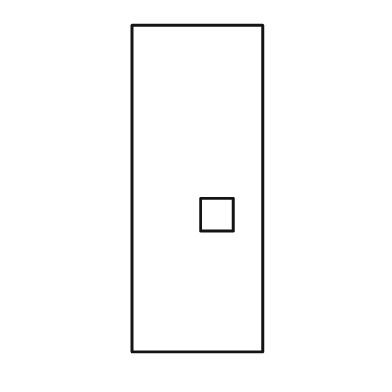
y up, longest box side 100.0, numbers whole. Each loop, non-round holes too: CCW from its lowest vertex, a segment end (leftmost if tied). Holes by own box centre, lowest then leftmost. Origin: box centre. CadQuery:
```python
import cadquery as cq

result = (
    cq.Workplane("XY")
    .moveTo(-20.0, -50.0)
    .lineTo(20.0, -50.0)
    .lineTo(20.0, 50.0)
    .lineTo(-20.0, 50.0)
    .close()
    .moveTo(1.0, -13.0)
    .lineTo(11.0, -13.0)
    .lineTo(11.0, -3.0)
    .lineTo(1.0, -3.0)
    .close()
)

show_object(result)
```